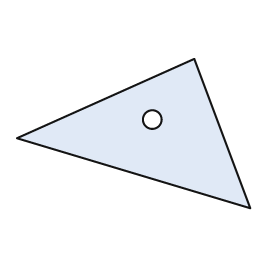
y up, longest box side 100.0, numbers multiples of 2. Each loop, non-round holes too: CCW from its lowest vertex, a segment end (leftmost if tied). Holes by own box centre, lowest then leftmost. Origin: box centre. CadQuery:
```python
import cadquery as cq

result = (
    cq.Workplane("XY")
    .moveTo(50.0, -32.0)
    .lineTo(26.0, 32.0)
    .lineTo(-50.0, -2.0)
    .close()
    .moveTo(8.0, 6.0)
    .circle(4.0)
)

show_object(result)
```